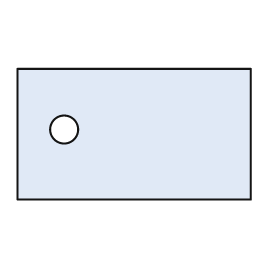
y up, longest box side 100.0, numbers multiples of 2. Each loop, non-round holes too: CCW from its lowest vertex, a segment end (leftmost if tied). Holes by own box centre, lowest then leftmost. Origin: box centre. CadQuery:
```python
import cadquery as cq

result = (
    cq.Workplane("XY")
    .moveTo(-50.0, -28.0)
    .lineTo(50.0, -28.0)
    .lineTo(50.0, 28.0)
    .lineTo(-50.0, 28.0)
    .close()
    .moveTo(-30.0, 2.0)
    .circle(6.0)
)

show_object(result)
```